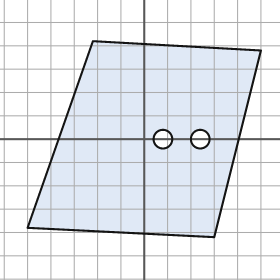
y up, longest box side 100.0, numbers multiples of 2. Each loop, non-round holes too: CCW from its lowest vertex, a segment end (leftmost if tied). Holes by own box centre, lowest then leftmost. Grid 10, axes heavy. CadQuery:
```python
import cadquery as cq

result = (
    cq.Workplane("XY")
    .moveTo(30.0, -42.0)
    .lineTo(50.0, 38.0)
    .lineTo(-22.0, 42.0)
    .lineTo(-50.0, -38.0)
    .close()
    .moveTo(8.0, 0.0)
    .circle(4.0)
    .moveTo(24.0, 0.0)
    .circle(4.0)
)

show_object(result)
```